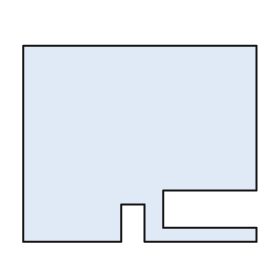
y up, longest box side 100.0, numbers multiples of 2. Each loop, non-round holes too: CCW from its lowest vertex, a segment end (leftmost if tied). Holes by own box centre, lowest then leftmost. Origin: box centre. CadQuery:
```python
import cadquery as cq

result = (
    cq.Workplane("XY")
    .moveTo(-50.0, -42.0)
    .lineTo(-8.0, -42.0)
    .lineTo(-8.0, -26.0)
    .lineTo(2.0, -26.0)
    .lineTo(2.0, -42.0)
    .lineTo(50.0, -42.0)
    .lineTo(50.0, -36.0)
    .lineTo(10.0, -36.0)
    .lineTo(10.0, -20.0)
    .lineTo(50.0, -20.0)
    .lineTo(50.0, 42.0)
    .lineTo(-50.0, 42.0)
    .close()
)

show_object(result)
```